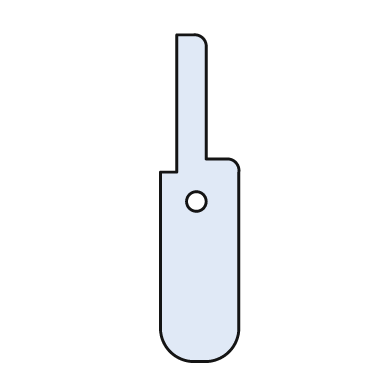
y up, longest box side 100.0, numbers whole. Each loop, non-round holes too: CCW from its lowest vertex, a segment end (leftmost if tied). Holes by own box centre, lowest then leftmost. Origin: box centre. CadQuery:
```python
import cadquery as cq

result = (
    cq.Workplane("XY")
    .moveTo(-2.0, -50.0)
    .lineTo(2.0, -50.0)
    .threePointArc((9.0, -47.0), (12.0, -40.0))
    .lineTo(12.0, 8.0)
    .threePointArc((11.0, 11.0), (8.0, 12.0))
    .lineTo(2.0, 12.0)
    .lineTo(2.0, 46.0)
    .threePointArc((1.0, 49.0), (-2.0, 50.0))
    .lineTo(-7.0, 50.0)
    .lineTo(-7.0, 8.0)
    .lineTo(-12.0, 8.0)
    .lineTo(-12.0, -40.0)
    .threePointArc((-9.0, -47.0), (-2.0, -50.0))
    .close()
    .moveTo(-1.0, -1.0)
    .circle(3.0)
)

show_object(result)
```